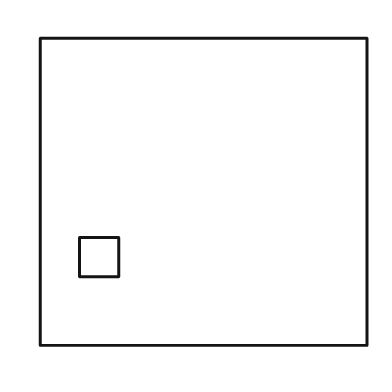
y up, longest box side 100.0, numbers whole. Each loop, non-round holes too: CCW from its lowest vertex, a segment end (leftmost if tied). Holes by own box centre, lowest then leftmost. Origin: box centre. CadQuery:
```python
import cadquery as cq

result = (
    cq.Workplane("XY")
    .moveTo(-50.0, -47.0)
    .lineTo(50.0, -47.0)
    .lineTo(50.0, 47.0)
    .lineTo(-50.0, 47.0)
    .close()
    .moveTo(-38.0, -26.0)
    .lineTo(-26.0, -26.0)
    .lineTo(-26.0, -14.0)
    .lineTo(-38.0, -14.0)
    .close()
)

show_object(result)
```